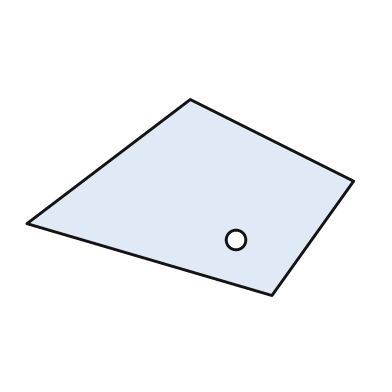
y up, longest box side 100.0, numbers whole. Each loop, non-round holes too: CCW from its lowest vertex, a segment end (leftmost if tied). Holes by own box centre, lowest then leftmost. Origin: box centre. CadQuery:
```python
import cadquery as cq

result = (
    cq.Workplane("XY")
    .moveTo(25.0, -30.0)
    .lineTo(50.0, 5.0)
    .lineTo(0.0, 30.0)
    .lineTo(-50.0, -8.0)
    .close()
    .moveTo(14.0, -13.0)
    .circle(3.0)
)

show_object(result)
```